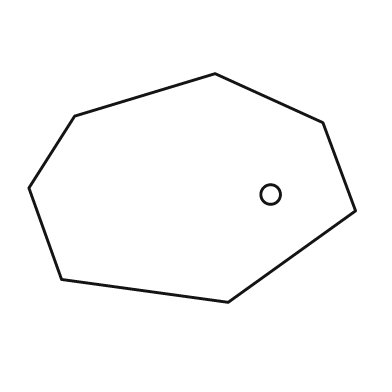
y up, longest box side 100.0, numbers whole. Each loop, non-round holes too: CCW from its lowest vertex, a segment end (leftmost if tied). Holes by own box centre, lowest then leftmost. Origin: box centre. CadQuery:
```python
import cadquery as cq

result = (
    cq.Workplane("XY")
    .moveTo(11.0, -35.0)
    .lineTo(50.0, -7.0)
    .lineTo(40.0, 20.0)
    .lineTo(7.0, 35.0)
    .lineTo(-36.0, 22.0)
    .lineTo(-50.0, 0.0)
    .lineTo(-40.0, -28.0)
    .close()
    .moveTo(24.0, -2.0)
    .circle(3.0)
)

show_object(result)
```